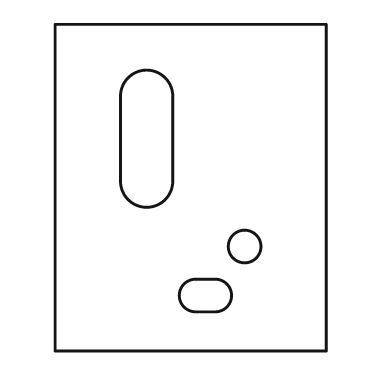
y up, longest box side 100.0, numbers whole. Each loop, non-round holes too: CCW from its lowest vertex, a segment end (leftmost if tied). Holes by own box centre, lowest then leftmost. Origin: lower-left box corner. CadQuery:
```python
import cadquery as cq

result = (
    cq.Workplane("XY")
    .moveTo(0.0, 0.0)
    .lineTo(83.0, 0.0)
    .lineTo(83.0, 100.0)
    .lineTo(0.0, 100.0)
    .close()
    .moveTo(43.0, 12.0)
    .lineTo(49.0, 12.0)
    .threePointArc((54.0, 17.0), (49.0, 22.0))
    .lineTo(43.0, 22.0)
    .threePointArc((38.0, 17.0), (43.0, 12.0))
    .close()
    .moveTo(58.0, 32.0)
    .circle(5.0)
    .moveTo(20.0, 52.0)
    .threePointArc((28.0, 44.0), (36.0, 52.0))
    .lineTo(36.0, 78.0)
    .threePointArc((28.0, 86.0), (20.0, 78.0))
    .close()
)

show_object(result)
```